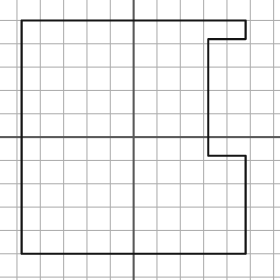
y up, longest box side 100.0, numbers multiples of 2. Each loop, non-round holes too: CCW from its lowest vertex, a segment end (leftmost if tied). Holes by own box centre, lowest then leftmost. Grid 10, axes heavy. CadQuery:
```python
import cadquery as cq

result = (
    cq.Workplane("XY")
    .moveTo(-48.0, -50.0)
    .lineTo(48.0, -50.0)
    .lineTo(48.0, -8.0)
    .lineTo(32.0, -8.0)
    .lineTo(32.0, 42.0)
    .lineTo(48.0, 42.0)
    .lineTo(48.0, 50.0)
    .lineTo(-48.0, 50.0)
    .close()
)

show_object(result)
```